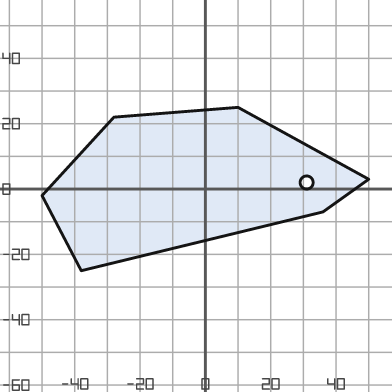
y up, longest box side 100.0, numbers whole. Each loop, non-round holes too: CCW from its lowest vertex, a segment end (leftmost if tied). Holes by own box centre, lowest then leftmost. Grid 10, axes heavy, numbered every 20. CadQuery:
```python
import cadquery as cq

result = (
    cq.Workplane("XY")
    .moveTo(-38.0, -25.0)
    .lineTo(36.0, -7.0)
    .lineTo(50.0, 3.0)
    .lineTo(10.0, 25.0)
    .lineTo(-28.0, 22.0)
    .lineTo(-50.0, -2.0)
    .close()
    .moveTo(31.0, 2.0)
    .circle(2.0)
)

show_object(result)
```